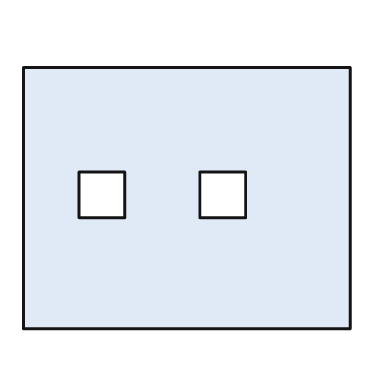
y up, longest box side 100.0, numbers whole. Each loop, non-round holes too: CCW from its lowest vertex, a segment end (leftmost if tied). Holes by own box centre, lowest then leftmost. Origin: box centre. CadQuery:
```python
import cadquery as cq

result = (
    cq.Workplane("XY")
    .moveTo(-50.0, -40.0)
    .lineTo(50.0, -40.0)
    .lineTo(50.0, 40.0)
    .lineTo(-50.0, 40.0)
    .close()
    .moveTo(-33.0, -6.0)
    .lineTo(-19.0, -6.0)
    .lineTo(-19.0, 8.0)
    .lineTo(-33.0, 8.0)
    .close()
    .moveTo(4.0, -6.0)
    .lineTo(18.0, -6.0)
    .lineTo(18.0, 8.0)
    .lineTo(4.0, 8.0)
    .close()
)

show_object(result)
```